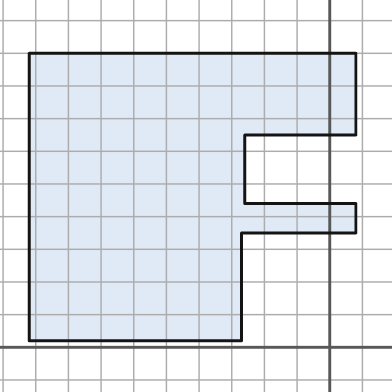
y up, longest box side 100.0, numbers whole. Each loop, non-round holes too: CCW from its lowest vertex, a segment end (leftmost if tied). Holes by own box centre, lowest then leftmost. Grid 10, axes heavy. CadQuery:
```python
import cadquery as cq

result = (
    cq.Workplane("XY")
    .moveTo(-92.0, 2.0)
    .lineTo(-27.0, 2.0)
    .lineTo(-27.0, 35.0)
    .lineTo(8.0, 35.0)
    .lineTo(8.0, 44.0)
    .lineTo(-26.0, 44.0)
    .lineTo(-26.0, 65.0)
    .lineTo(8.0, 65.0)
    .lineTo(8.0, 90.0)
    .lineTo(-92.0, 90.0)
    .close()
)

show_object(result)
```